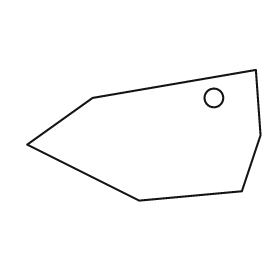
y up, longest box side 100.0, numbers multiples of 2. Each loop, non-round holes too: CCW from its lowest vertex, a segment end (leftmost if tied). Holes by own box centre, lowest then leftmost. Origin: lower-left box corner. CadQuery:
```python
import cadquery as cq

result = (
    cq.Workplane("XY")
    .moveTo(48.0, 0.0)
    .lineTo(92.0, 4.0)
    .lineTo(100.0, 28.0)
    .lineTo(98.0, 56.0)
    .lineTo(28.0, 44.0)
    .lineTo(0.0, 24.0)
    .close()
    .moveTo(80.0, 44.0)
    .circle(4.0)
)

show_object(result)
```